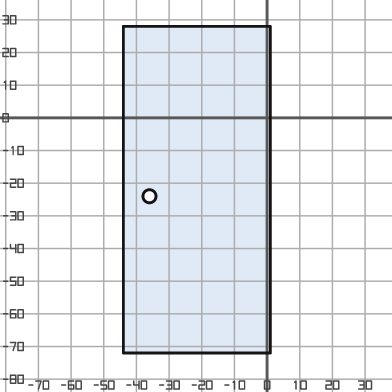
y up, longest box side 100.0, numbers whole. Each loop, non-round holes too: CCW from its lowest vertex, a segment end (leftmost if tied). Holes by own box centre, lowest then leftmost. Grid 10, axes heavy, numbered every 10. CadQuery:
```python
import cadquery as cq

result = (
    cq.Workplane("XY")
    .moveTo(-44.0, -72.0)
    .lineTo(1.0, -72.0)
    .lineTo(1.0, 28.0)
    .lineTo(-44.0, 28.0)
    .close()
    .moveTo(-36.0, -24.0)
    .circle(2.0)
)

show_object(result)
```